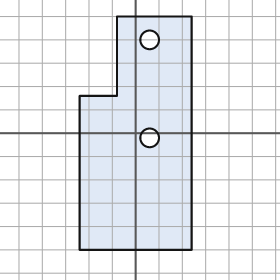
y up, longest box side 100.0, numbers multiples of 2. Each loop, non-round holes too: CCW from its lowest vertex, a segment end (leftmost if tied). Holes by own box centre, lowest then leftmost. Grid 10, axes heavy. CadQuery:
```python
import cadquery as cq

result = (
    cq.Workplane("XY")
    .moveTo(-24.0, -50.0)
    .lineTo(24.0, -50.0)
    .lineTo(24.0, 50.0)
    .lineTo(-8.0, 50.0)
    .lineTo(-8.0, 16.0)
    .lineTo(-24.0, 16.0)
    .close()
    .moveTo(6.0, -2.0)
    .circle(4.0)
    .moveTo(6.0, 40.0)
    .circle(4.0)
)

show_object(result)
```